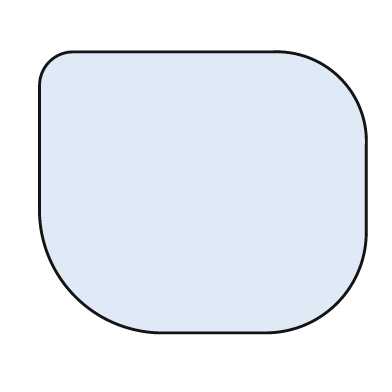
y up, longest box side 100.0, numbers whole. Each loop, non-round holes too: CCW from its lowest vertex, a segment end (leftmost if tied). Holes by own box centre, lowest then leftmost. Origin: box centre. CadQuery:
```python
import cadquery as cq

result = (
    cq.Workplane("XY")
    .moveTo(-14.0, -43.0)
    .lineTo(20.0, -43.0)
    .threePointArc((41.0, -34.0), (50.0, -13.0))
    .lineTo(50.0, 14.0)
    .threePointArc((42.0, 35.0), (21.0, 43.0))
    .lineTo(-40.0, 43.0)
    .threePointArc((-47.0, 40.0), (-50.0, 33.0))
    .lineTo(-50.0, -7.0)
    .threePointArc((-39.0, -32.0), (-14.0, -43.0))
    .close()
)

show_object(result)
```